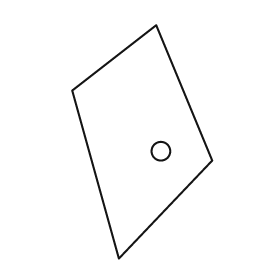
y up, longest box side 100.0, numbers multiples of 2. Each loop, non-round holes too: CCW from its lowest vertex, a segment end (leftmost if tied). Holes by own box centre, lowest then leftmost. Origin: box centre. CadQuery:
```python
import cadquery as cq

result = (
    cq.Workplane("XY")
    .moveTo(-10.0, -50.0)
    .lineTo(30.0, -8.0)
    .lineTo(6.0, 50.0)
    .lineTo(-30.0, 22.0)
    .close()
    .moveTo(8.0, -4.0)
    .circle(4.0)
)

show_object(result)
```